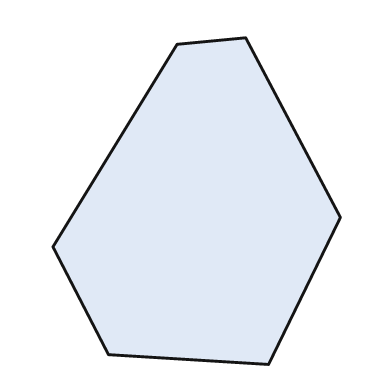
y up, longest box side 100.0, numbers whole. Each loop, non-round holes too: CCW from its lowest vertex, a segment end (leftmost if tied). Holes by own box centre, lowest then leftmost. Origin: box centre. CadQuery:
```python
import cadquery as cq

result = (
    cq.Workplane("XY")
    .moveTo(22.0, -50.0)
    .lineTo(44.0, -5.0)
    .lineTo(15.0, 50.0)
    .lineTo(-6.0, 48.0)
    .lineTo(-44.0, -14.0)
    .lineTo(-27.0, -47.0)
    .close()
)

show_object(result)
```